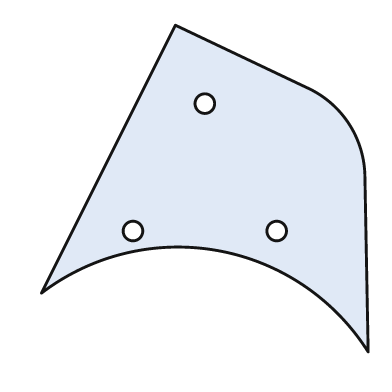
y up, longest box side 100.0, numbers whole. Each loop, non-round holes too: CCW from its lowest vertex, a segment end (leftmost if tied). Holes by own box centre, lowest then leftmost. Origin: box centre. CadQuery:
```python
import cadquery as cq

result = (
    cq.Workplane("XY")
    .moveTo(50.0, -50.0)
    .lineTo(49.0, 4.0)
    .threePointArc((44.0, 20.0), (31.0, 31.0))
    .lineTo(-9.0, 50.0)
    .lineTo(-50.0, -32.0)
    .threePointArc((4.0, -19.0), (50.0, -50.0))
    .close()
    .moveTo(-22.0, -13.0)
    .circle(3.0)
    .moveTo(22.0, -13.0)
    .circle(3.0)
    .moveTo(0.0, 26.0)
    .circle(3.0)
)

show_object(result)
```